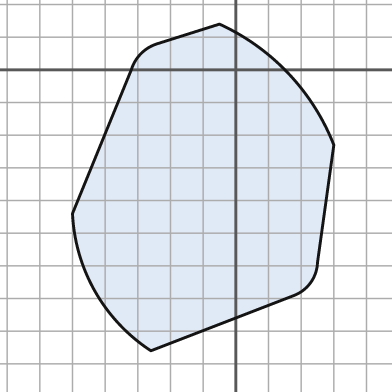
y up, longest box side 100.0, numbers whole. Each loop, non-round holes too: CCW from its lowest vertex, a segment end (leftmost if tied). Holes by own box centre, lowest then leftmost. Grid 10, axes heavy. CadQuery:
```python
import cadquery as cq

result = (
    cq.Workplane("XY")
    .moveTo(-26.0, -86.0)
    .lineTo(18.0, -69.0)
    .threePointArc((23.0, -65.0), (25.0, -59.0))
    .lineTo(30.0, -23.0)
    .threePointArc((16.0, -1.0), (-5.0, 14.0))
    .lineTo(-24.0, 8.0)
    .threePointArc((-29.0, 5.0), (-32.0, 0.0))
    .lineTo(-50.0, -44.0)
    .threePointArc((-43.0, -68.0), (-26.0, -86.0))
    .close()
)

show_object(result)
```